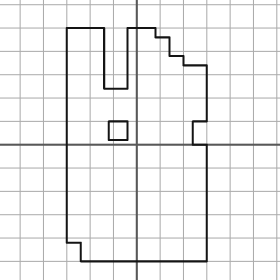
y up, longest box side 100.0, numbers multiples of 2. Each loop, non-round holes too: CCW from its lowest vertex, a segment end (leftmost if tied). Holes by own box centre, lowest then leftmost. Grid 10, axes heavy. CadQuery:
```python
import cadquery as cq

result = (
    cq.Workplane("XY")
    .moveTo(-24.0, -50.0)
    .lineTo(30.0, -50.0)
    .lineTo(30.0, 0.0)
    .lineTo(24.0, 0.0)
    .lineTo(24.0, 10.0)
    .lineTo(30.0, 10.0)
    .lineTo(30.0, 34.0)
    .lineTo(20.0, 34.0)
    .lineTo(20.0, 38.0)
    .lineTo(14.0, 38.0)
    .lineTo(14.0, 46.0)
    .lineTo(8.0, 46.0)
    .lineTo(8.0, 50.0)
    .lineTo(-4.0, 50.0)
    .lineTo(-4.0, 24.0)
    .lineTo(-14.0, 24.0)
    .lineTo(-14.0, 50.0)
    .lineTo(-30.0, 50.0)
    .lineTo(-30.0, -42.0)
    .lineTo(-24.0, -42.0)
    .close()
    .moveTo(-12.0, 2.0)
    .lineTo(-4.0, 2.0)
    .lineTo(-4.0, 10.0)
    .lineTo(-12.0, 10.0)
    .close()
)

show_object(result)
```